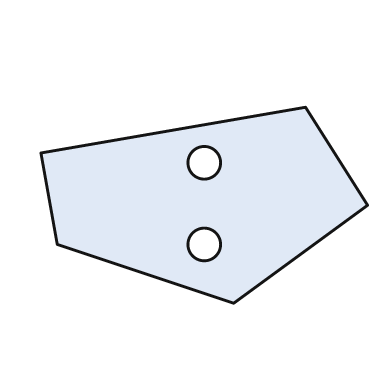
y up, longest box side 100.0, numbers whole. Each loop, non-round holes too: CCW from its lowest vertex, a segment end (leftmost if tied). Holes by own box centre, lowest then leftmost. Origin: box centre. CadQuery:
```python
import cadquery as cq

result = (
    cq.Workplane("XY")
    .moveTo(9.0, -30.0)
    .lineTo(50.0, 0.0)
    .lineTo(31.0, 30.0)
    .lineTo(-50.0, 16.0)
    .lineTo(-45.0, -12.0)
    .close()
    .moveTo(0.0, -12.0)
    .circle(5.0)
    .moveTo(0.0, 13.0)
    .circle(5.0)
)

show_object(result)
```